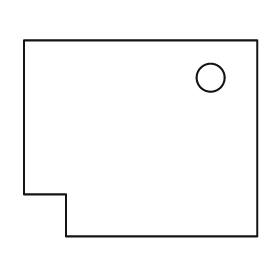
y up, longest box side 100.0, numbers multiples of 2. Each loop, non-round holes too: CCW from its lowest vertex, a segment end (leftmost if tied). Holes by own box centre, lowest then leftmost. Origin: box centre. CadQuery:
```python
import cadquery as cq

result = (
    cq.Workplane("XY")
    .moveTo(-32.0, -42.0)
    .lineTo(50.0, -42.0)
    .lineTo(50.0, 42.0)
    .lineTo(-50.0, 42.0)
    .lineTo(-50.0, -24.0)
    .lineTo(-32.0, -24.0)
    .close()
    .moveTo(30.0, 26.0)
    .circle(6.0)
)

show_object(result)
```